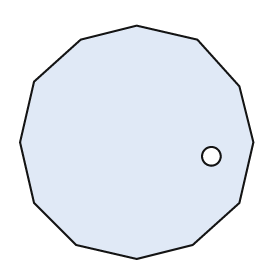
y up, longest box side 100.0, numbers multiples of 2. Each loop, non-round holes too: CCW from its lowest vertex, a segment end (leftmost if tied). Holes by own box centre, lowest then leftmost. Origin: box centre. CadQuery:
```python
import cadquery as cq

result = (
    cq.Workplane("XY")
    .moveTo(0.0, -50.0)
    .lineTo(24.0, -44.0)
    .lineTo(44.0, -26.0)
    .lineTo(50.0, 0.0)
    .lineTo(44.0, 24.0)
    .lineTo(26.0, 44.0)
    .lineTo(0.0, 50.0)
    .lineTo(-24.0, 44.0)
    .lineTo(-44.0, 26.0)
    .lineTo(-50.0, 0.0)
    .lineTo(-44.0, -26.0)
    .lineTo(-26.0, -44.0)
    .close()
    .moveTo(32.0, -6.0)
    .circle(4.0)
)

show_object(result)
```